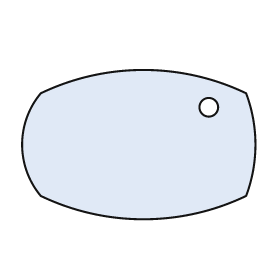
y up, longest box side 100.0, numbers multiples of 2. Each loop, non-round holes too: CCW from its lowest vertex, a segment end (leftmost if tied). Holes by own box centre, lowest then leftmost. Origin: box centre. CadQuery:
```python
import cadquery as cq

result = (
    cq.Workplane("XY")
    .moveTo(-42.0, -22.0)
    .threePointArc((2.0, -32.0), (46.0, -22.0))
    .threePointArc((50.0, 0.0), (46.0, 22.0))
    .threePointArc((2.0, 32.0), (-42.0, 22.0))
    .threePointArc((-50.0, 0.0), (-42.0, -22.0))
    .close()
    .moveTo(30.0, 16.0)
    .circle(4.0)
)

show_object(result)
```